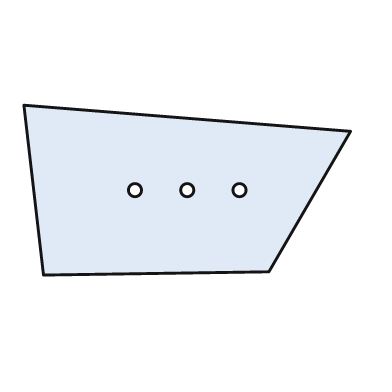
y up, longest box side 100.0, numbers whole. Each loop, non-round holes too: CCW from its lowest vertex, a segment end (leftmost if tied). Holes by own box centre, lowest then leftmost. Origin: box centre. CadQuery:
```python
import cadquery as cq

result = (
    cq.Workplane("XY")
    .moveTo(-44.0, -26.0)
    .lineTo(25.0, -25.0)
    .lineTo(50.0, 18.0)
    .lineTo(-50.0, 26.0)
    .close()
    .moveTo(-16.0, 0.0)
    .circle(2.0)
    .moveTo(0.0, 0.0)
    .circle(2.0)
    .moveTo(16.0, 0.0)
    .circle(2.0)
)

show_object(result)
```